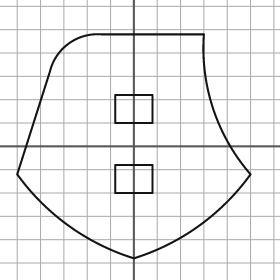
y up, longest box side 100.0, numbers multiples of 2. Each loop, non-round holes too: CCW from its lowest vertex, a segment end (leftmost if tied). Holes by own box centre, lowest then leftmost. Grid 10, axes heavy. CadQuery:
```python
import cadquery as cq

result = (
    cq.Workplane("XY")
    .moveTo(0.0, -48.0)
    .threePointArc((28.0, -34.0), (50.0, -12.0))
    .threePointArc((34.0, 16.0), (30.0, 48.0))
    .lineTo(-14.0, 48.0)
    .threePointArc((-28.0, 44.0), (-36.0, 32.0))
    .lineTo(-50.0, -12.0)
    .threePointArc((-28.0, -34.0), (0.0, -48.0))
    .close()
    .moveTo(-8.0, -20.0)
    .lineTo(8.0, -20.0)
    .lineTo(8.0, -8.0)
    .lineTo(-8.0, -8.0)
    .close()
    .moveTo(-8.0, 10.0)
    .lineTo(8.0, 10.0)
    .lineTo(8.0, 22.0)
    .lineTo(-8.0, 22.0)
    .close()
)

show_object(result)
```